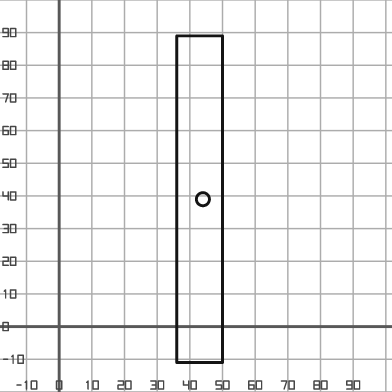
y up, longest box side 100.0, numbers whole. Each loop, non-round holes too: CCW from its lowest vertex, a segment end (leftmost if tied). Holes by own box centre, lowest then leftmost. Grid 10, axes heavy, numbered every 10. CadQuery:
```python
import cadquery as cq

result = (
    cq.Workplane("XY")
    .moveTo(36.0, -11.0)
    .lineTo(50.0, -11.0)
    .lineTo(50.0, 89.0)
    .lineTo(36.0, 89.0)
    .close()
    .moveTo(44.0, 39.0)
    .circle(2.0)
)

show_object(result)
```